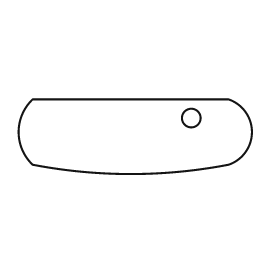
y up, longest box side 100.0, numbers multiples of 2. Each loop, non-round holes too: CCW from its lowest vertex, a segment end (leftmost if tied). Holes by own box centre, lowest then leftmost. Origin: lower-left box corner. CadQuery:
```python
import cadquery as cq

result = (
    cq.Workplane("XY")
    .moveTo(6.0, 4.0)
    .threePointArc((48.0, 0.0), (90.0, 4.0))
    .threePointArc((100.0, 18.0), (90.0, 32.0))
    .lineTo(6.0, 32.0)
    .threePointArc((0.0, 18.0), (6.0, 4.0))
    .close()
    .moveTo(74.0, 24.0)
    .circle(4.0)
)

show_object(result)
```